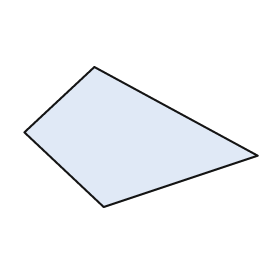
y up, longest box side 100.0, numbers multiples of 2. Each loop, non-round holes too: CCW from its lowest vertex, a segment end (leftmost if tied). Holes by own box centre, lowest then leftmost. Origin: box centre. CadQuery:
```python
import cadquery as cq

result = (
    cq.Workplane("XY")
    .moveTo(-16.0, -30.0)
    .lineTo(50.0, -8.0)
    .lineTo(-20.0, 30.0)
    .lineTo(-50.0, 2.0)
    .close()
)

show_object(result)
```